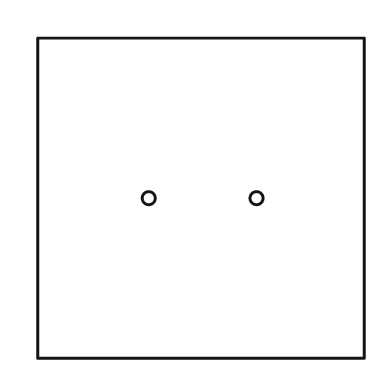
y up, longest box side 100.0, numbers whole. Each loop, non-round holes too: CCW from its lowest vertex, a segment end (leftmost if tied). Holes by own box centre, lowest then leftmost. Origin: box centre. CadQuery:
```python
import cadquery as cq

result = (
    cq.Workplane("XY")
    .moveTo(-50.0, -49.0)
    .lineTo(50.0, -49.0)
    .lineTo(50.0, 49.0)
    .lineTo(-50.0, 49.0)
    .close()
    .moveTo(-16.0, 0.0)
    .circle(2.0)
    .moveTo(17.0, 0.0)
    .circle(2.0)
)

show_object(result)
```